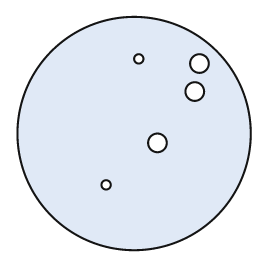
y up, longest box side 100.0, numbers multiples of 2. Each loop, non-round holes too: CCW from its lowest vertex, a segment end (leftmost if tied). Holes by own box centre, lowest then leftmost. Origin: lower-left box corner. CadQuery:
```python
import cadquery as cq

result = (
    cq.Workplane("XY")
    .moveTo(50.0, 50.0)
    .circle(50.0)
    .moveTo(38.0, 28.0)
    .circle(2.0)
    .moveTo(60.0, 46.0)
    .circle(4.0)
    .moveTo(76.0, 68.0)
    .circle(4.0)
    .moveTo(78.0, 80.0)
    .circle(4.0)
    .moveTo(52.0, 82.0)
    .circle(2.0)
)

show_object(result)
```